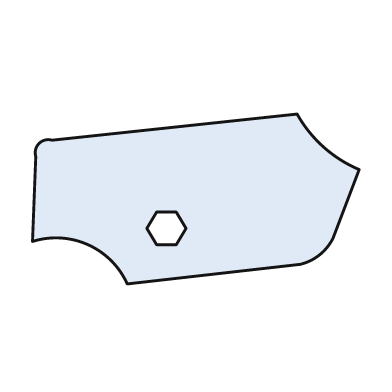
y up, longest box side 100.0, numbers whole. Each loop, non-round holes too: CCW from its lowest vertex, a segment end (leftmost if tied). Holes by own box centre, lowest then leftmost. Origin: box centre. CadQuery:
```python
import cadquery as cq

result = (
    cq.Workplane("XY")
    .moveTo(-21.0, -26.0)
    .lineTo(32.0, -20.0)
    .threePointArc((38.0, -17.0), (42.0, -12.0))
    .lineTo(50.0, 9.0)
    .threePointArc((39.0, 16.0), (31.0, 26.0))
    .lineTo(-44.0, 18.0)
    .threePointArc((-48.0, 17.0), (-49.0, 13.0))
    .lineTo(-50.0, -13.0)
    .threePointArc((-33.0, -14.0), (-21.0, -26.0))
    .close()
    .moveTo(-12.0, -14.0)
    .lineTo(-6.0, -14.0)
    .lineTo(-3.0, -9.0)
    .lineTo(-6.0, -4.0)
    .lineTo(-12.0, -4.0)
    .lineTo(-15.0, -9.0)
    .close()
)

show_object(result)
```